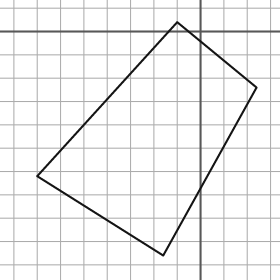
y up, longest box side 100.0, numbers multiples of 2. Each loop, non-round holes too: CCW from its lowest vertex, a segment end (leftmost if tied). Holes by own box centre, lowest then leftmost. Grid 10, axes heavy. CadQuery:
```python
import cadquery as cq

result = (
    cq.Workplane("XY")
    .moveTo(-16.0, -96.0)
    .lineTo(24.0, -24.0)
    .lineTo(-10.0, 4.0)
    .lineTo(-70.0, -62.0)
    .close()
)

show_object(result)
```